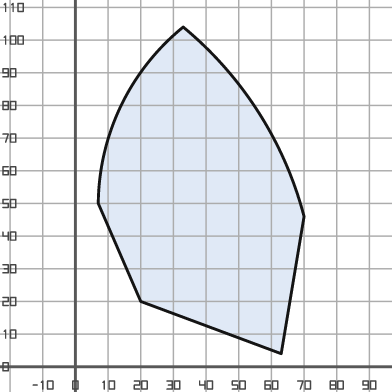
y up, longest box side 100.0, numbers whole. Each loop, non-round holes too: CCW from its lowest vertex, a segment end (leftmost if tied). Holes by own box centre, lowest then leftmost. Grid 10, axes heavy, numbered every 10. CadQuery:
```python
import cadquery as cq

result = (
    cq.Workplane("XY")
    .moveTo(63.0, 4.0)
    .lineTo(70.0, 46.0)
    .threePointArc((56.0, 78.0), (33.0, 104.0))
    .threePointArc((14.0, 80.0), (7.0, 50.0))
    .lineTo(20.0, 20.0)
    .close()
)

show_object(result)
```